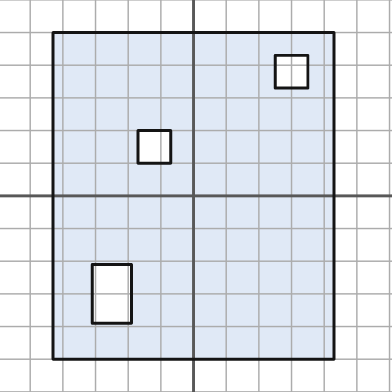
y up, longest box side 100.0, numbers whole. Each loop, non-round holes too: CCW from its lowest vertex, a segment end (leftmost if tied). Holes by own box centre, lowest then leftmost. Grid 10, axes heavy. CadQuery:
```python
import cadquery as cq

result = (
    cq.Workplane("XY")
    .moveTo(-43.0, -50.0)
    .lineTo(43.0, -50.0)
    .lineTo(43.0, 50.0)
    .lineTo(-43.0, 50.0)
    .close()
    .moveTo(-31.0, -39.0)
    .lineTo(-19.0, -39.0)
    .lineTo(-19.0, -21.0)
    .lineTo(-31.0, -21.0)
    .close()
    .moveTo(-17.0, 10.0)
    .lineTo(-7.0, 10.0)
    .lineTo(-7.0, 20.0)
    .lineTo(-17.0, 20.0)
    .close()
    .moveTo(25.0, 33.0)
    .lineTo(35.0, 33.0)
    .lineTo(35.0, 43.0)
    .lineTo(25.0, 43.0)
    .close()
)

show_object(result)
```